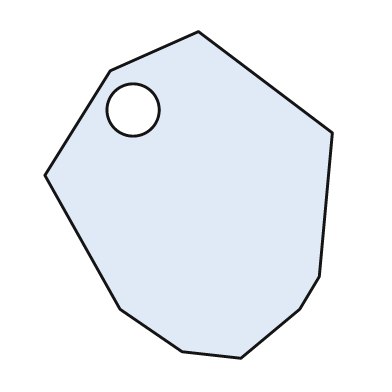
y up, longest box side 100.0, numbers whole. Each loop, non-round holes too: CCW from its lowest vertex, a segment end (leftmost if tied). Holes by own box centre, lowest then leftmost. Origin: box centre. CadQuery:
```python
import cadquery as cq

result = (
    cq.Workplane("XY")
    .moveTo(16.0, -50.0)
    .lineTo(34.0, -35.0)
    .lineTo(40.0, -25.0)
    .lineTo(44.0, 19.0)
    .lineTo(3.0, 50.0)
    .lineTo(-24.0, 38.0)
    .lineTo(-44.0, 6.0)
    .lineTo(-21.0, -35.0)
    .lineTo(-2.0, -48.0)
    .close()
    .moveTo(-17.0, 26.0)
    .circle(8.0)
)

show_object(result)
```